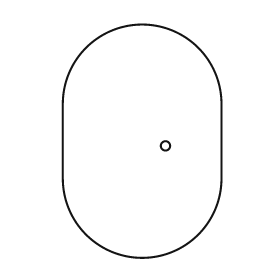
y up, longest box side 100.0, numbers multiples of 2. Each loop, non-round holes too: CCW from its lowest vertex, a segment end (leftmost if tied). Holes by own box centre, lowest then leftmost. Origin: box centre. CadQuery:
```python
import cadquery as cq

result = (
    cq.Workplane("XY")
    .moveTo(-34.0, -16.0)
    .threePointArc((0.0, -50.0), (34.0, -16.0))
    .lineTo(34.0, 16.0)
    .threePointArc((0.0, 50.0), (-34.0, 16.0))
    .close()
    .moveTo(10.0, -2.0)
    .circle(2.0)
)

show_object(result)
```